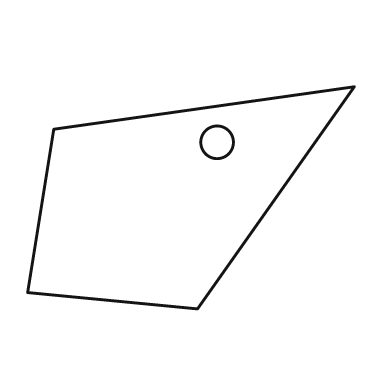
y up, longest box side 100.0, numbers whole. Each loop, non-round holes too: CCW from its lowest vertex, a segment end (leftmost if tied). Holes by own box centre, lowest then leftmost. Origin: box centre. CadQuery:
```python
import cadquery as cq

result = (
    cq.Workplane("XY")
    .moveTo(2.0, -34.0)
    .lineTo(50.0, 34.0)
    .lineTo(-42.0, 21.0)
    .lineTo(-50.0, -29.0)
    .close()
    .moveTo(8.0, 17.0)
    .circle(5.0)
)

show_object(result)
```